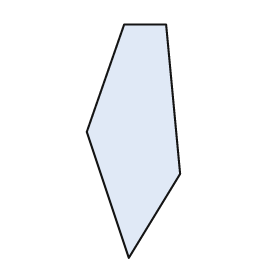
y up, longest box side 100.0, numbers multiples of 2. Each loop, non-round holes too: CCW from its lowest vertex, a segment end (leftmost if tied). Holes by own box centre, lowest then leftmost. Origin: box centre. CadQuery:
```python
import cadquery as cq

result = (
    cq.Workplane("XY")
    .moveTo(-2.0, -50.0)
    .lineTo(20.0, -14.0)
    .lineTo(14.0, 50.0)
    .lineTo(-4.0, 50.0)
    .lineTo(-20.0, 4.0)
    .close()
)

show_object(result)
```